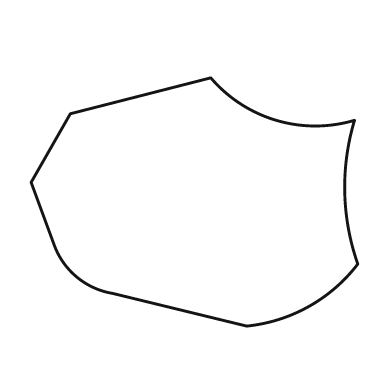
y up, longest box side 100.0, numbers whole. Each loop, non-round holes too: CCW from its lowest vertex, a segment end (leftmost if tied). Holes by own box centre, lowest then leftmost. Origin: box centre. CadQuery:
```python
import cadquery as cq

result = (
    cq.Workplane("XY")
    .moveTo(16.0, -38.0)
    .threePointArc((35.0, -32.0), (50.0, -19.0))
    .threePointArc((46.0, 3.0), (49.0, 25.0))
    .threePointArc((25.0, 25.0), (5.0, 38.0))
    .lineTo(-38.0, 27.0)
    .lineTo(-50.0, 6.0)
    .lineTo(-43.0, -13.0)
    .threePointArc((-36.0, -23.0), (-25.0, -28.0))
    .close()
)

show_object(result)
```